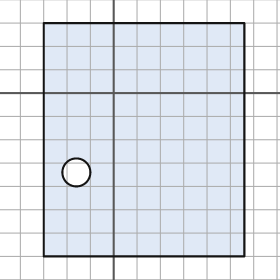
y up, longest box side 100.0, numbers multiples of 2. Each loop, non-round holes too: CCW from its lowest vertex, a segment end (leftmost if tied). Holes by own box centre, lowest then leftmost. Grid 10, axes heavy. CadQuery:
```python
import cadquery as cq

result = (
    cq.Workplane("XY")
    .moveTo(-30.0, -70.0)
    .lineTo(56.0, -70.0)
    .lineTo(56.0, 30.0)
    .lineTo(-30.0, 30.0)
    .close()
    .moveTo(-16.0, -34.0)
    .circle(6.0)
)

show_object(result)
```